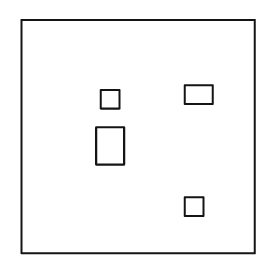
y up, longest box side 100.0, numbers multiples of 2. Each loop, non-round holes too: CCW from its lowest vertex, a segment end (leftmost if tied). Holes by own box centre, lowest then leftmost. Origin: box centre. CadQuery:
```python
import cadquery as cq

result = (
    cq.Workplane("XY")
    .moveTo(-50.0, -50.0)
    .lineTo(50.0, -50.0)
    .lineTo(50.0, 50.0)
    .lineTo(-50.0, 50.0)
    .close()
    .moveTo(20.0, -34.0)
    .lineTo(28.0, -34.0)
    .lineTo(28.0, -26.0)
    .lineTo(20.0, -26.0)
    .close()
    .moveTo(-18.0, -12.0)
    .lineTo(-6.0, -12.0)
    .lineTo(-6.0, 4.0)
    .lineTo(-18.0, 4.0)
    .close()
    .moveTo(-16.0, 12.0)
    .lineTo(-8.0, 12.0)
    .lineTo(-8.0, 20.0)
    .lineTo(-16.0, 20.0)
    .close()
    .moveTo(20.0, 14.0)
    .lineTo(32.0, 14.0)
    .lineTo(32.0, 22.0)
    .lineTo(20.0, 22.0)
    .close()
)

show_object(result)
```